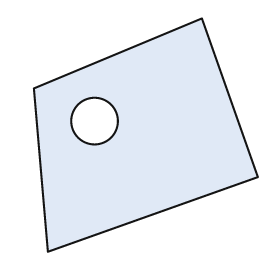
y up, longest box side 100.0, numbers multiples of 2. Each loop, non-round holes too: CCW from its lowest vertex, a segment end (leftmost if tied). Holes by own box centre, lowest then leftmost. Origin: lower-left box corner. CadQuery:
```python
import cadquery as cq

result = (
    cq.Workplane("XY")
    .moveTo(6.0, 0.0)
    .lineTo(96.0, 32.0)
    .lineTo(72.0, 100.0)
    .lineTo(0.0, 70.0)
    .close()
    .moveTo(26.0, 56.0)
    .circle(10.0)
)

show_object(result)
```